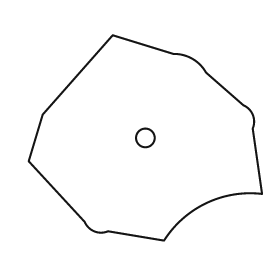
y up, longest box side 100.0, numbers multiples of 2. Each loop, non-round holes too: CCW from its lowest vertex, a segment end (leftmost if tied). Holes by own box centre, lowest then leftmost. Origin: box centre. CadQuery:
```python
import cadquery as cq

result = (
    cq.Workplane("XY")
    .moveTo(8.0, -44.0)
    .threePointArc((26.0, -28.0), (50.0, -24.0))
    .lineTo(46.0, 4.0)
    .threePointArc((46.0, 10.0), (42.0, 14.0))
    .lineTo(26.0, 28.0)
    .threePointArc((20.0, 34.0), (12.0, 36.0))
    .lineTo(-14.0, 44.0)
    .lineTo(-44.0, 10.0)
    .lineTo(-50.0, -10.0)
    .lineTo(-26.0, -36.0)
    .threePointArc((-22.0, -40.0), (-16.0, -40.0))
    .close()
    .moveTo(0.0, 0.0)
    .circle(4.0)
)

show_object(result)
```